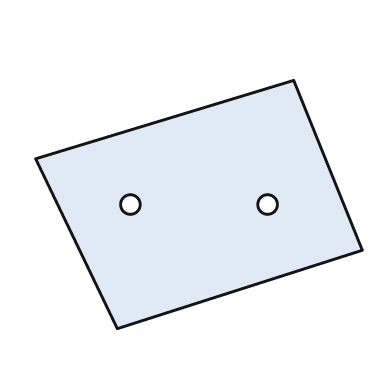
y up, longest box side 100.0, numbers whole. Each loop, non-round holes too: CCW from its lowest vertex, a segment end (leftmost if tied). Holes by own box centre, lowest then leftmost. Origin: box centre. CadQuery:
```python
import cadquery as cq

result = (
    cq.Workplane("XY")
    .moveTo(-25.0, -38.0)
    .lineTo(50.0, -14.0)
    .lineTo(29.0, 38.0)
    .lineTo(-50.0, 14.0)
    .close()
    .moveTo(-21.0, 0.0)
    .circle(3.0)
    .moveTo(21.0, 0.0)
    .circle(3.0)
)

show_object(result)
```